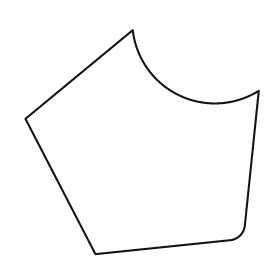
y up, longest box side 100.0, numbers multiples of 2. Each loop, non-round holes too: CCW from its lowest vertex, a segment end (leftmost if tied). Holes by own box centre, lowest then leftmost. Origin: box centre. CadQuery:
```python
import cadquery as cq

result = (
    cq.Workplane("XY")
    .moveTo(-20.0, -48.0)
    .lineTo(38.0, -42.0)
    .threePointArc((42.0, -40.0), (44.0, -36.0))
    .lineTo(50.0, 22.0)
    .threePointArc((16.0, 20.0), (-4.0, 48.0))
    .lineTo(-50.0, 10.0)
    .close()
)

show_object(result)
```